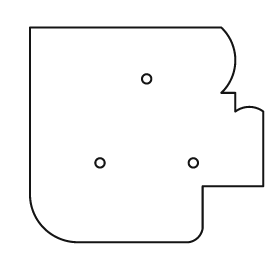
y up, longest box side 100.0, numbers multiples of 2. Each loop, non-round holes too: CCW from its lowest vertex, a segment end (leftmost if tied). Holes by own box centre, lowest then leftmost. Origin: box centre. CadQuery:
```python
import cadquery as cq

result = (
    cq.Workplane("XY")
    .moveTo(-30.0, -46.0)
    .lineTo(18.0, -46.0)
    .threePointArc((22.0, -44.0), (24.0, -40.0))
    .lineTo(24.0, -22.0)
    .lineTo(50.0, -22.0)
    .lineTo(50.0, 10.0)
    .threePointArc((44.0, 12.0), (38.0, 10.0))
    .lineTo(38.0, 18.0)
    .lineTo(32.0, 18.0)
    .threePointArc((38.0, 32.0), (32.0, 46.0))
    .lineTo(-50.0, 46.0)
    .lineTo(-50.0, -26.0)
    .threePointArc((-44.0, -40.0), (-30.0, -46.0))
    .close()
    .moveTo(-20.0, -12.0)
    .circle(2.0)
    .moveTo(20.0, -12.0)
    .circle(2.0)
    .moveTo(0.0, 24.0)
    .circle(2.0)
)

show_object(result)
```